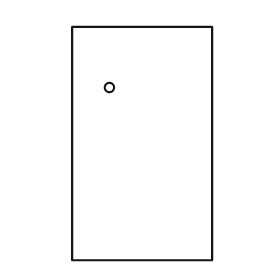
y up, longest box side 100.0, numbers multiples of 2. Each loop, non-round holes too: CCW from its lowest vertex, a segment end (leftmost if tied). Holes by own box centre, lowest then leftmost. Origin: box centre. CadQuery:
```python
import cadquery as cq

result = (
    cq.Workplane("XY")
    .moveTo(-30.0, -50.0)
    .lineTo(30.0, -50.0)
    .lineTo(30.0, 50.0)
    .lineTo(-30.0, 50.0)
    .close()
    .moveTo(-14.0, 24.0)
    .circle(2.0)
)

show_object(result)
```